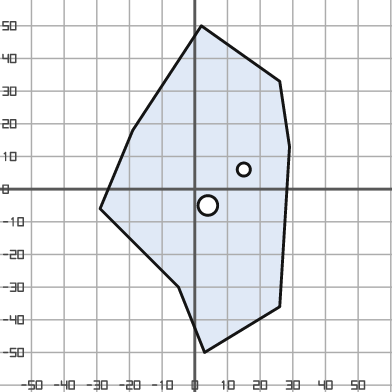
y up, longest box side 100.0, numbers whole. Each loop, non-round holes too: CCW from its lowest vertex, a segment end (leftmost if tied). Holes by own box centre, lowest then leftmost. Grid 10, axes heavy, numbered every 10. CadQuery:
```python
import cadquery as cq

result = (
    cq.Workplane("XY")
    .moveTo(3.0, -50.0)
    .lineTo(26.0, -36.0)
    .lineTo(29.0, 13.0)
    .lineTo(26.0, 33.0)
    .lineTo(2.0, 50.0)
    .lineTo(-19.0, 18.0)
    .lineTo(-29.0, -6.0)
    .lineTo(-5.0, -30.0)
    .close()
    .moveTo(4.0, -5.0)
    .circle(3.0)
    .moveTo(15.0, 6.0)
    .circle(2.0)
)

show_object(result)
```